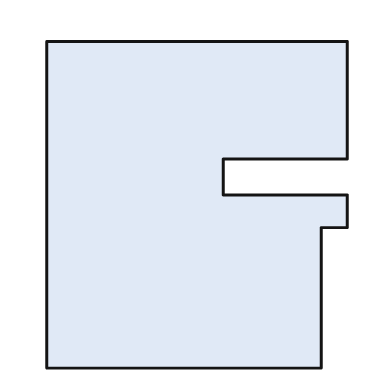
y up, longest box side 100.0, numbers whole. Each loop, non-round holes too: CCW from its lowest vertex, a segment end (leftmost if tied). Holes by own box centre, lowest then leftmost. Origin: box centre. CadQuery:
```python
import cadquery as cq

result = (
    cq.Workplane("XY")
    .moveTo(-46.0, -50.0)
    .lineTo(38.0, -50.0)
    .lineTo(38.0, -7.0)
    .lineTo(46.0, -7.0)
    .lineTo(46.0, 3.0)
    .lineTo(8.0, 3.0)
    .lineTo(8.0, 14.0)
    .lineTo(46.0, 14.0)
    .lineTo(46.0, 50.0)
    .lineTo(-46.0, 50.0)
    .close()
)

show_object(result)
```